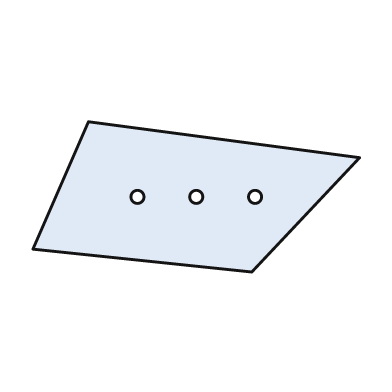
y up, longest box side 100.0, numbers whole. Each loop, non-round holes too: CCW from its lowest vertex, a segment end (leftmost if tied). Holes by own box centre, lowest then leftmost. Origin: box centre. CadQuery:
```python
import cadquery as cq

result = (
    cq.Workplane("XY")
    .moveTo(17.0, -23.0)
    .lineTo(50.0, 12.0)
    .lineTo(-33.0, 23.0)
    .lineTo(-50.0, -16.0)
    .close()
    .moveTo(-18.0, 0.0)
    .circle(2.0)
    .moveTo(0.0, 0.0)
    .circle(2.0)
    .moveTo(18.0, 0.0)
    .circle(2.0)
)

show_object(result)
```